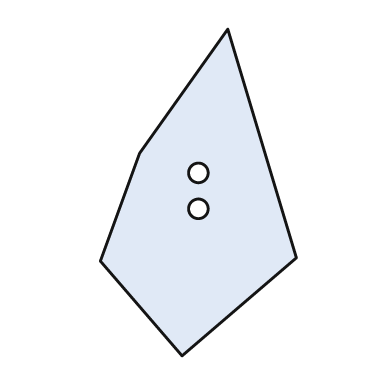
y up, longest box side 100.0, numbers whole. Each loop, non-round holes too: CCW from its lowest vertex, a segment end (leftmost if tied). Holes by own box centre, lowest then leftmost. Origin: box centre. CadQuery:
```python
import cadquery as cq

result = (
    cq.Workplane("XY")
    .moveTo(-5.0, -50.0)
    .lineTo(30.0, -20.0)
    .lineTo(9.0, 50.0)
    .lineTo(-18.0, 12.0)
    .lineTo(-30.0, -21.0)
    .close()
    .moveTo(0.0, -5.0)
    .circle(3.0)
    .moveTo(0.0, 6.0)
    .circle(3.0)
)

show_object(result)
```